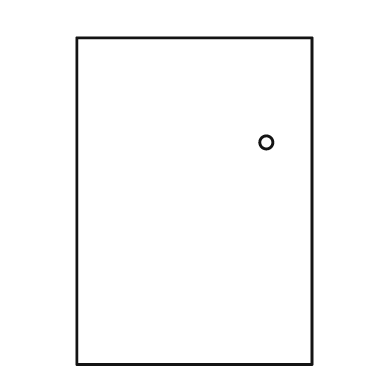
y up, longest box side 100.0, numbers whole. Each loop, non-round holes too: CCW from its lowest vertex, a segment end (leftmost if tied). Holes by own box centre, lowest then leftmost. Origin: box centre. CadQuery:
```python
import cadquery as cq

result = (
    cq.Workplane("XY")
    .moveTo(-36.0, -50.0)
    .lineTo(36.0, -50.0)
    .lineTo(36.0, 50.0)
    .lineTo(-36.0, 50.0)
    .close()
    .moveTo(22.0, 18.0)
    .circle(2.0)
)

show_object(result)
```